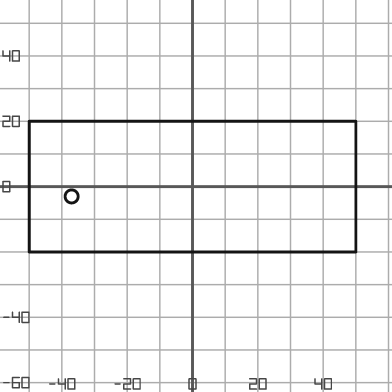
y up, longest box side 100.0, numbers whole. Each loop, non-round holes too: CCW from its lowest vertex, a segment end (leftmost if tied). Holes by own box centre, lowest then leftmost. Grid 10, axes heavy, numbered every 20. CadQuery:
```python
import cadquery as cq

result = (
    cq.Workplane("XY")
    .moveTo(-50.0, -20.0)
    .lineTo(50.0, -20.0)
    .lineTo(50.0, 20.0)
    .lineTo(-50.0, 20.0)
    .close()
    .moveTo(-37.0, -3.0)
    .circle(2.0)
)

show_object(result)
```